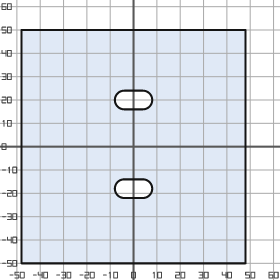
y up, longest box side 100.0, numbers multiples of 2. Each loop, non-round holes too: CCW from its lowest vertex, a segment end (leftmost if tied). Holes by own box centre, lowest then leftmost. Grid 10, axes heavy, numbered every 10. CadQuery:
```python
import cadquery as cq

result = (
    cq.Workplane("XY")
    .moveTo(-48.0, -50.0)
    .lineTo(48.0, -50.0)
    .lineTo(48.0, 50.0)
    .lineTo(-48.0, 50.0)
    .close()
    .moveTo(-4.0, -22.0)
    .lineTo(4.0, -22.0)
    .threePointArc((8.0, -18.0), (4.0, -14.0))
    .lineTo(-4.0, -14.0)
    .threePointArc((-8.0, -18.0), (-4.0, -22.0))
    .close()
    .moveTo(-4.0, 16.0)
    .lineTo(4.0, 16.0)
    .threePointArc((8.0, 20.0), (4.0, 24.0))
    .lineTo(-4.0, 24.0)
    .threePointArc((-8.0, 20.0), (-4.0, 16.0))
    .close()
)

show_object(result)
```